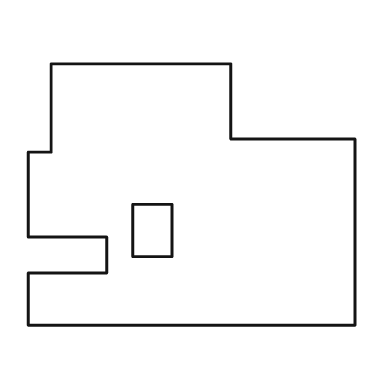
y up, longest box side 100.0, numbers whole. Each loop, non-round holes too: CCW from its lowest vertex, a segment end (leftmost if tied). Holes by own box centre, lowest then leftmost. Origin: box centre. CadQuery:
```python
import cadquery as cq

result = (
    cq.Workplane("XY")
    .moveTo(-50.0, -40.0)
    .lineTo(50.0, -40.0)
    .lineTo(50.0, 17.0)
    .lineTo(12.0, 17.0)
    .lineTo(12.0, 40.0)
    .lineTo(-43.0, 40.0)
    .lineTo(-43.0, 13.0)
    .lineTo(-50.0, 13.0)
    .lineTo(-50.0, -13.0)
    .lineTo(-26.0, -13.0)
    .lineTo(-26.0, -24.0)
    .lineTo(-50.0, -24.0)
    .close()
    .moveTo(-18.0, -19.0)
    .lineTo(-6.0, -19.0)
    .lineTo(-6.0, -3.0)
    .lineTo(-18.0, -3.0)
    .close()
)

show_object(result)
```